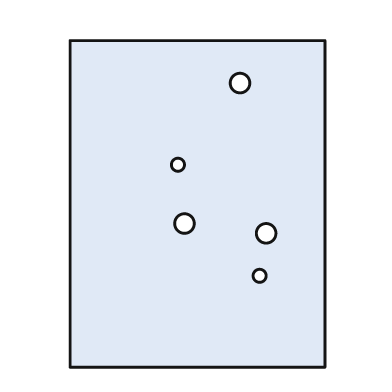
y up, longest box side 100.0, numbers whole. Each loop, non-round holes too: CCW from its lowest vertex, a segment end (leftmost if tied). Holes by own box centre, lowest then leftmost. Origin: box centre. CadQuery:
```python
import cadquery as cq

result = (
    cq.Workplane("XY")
    .moveTo(-39.0, -50.0)
    .lineTo(39.0, -50.0)
    .lineTo(39.0, 50.0)
    .lineTo(-39.0, 50.0)
    .close()
    .moveTo(19.0, -22.0)
    .circle(2.0)
    .moveTo(21.0, -9.0)
    .circle(3.0)
    .moveTo(-4.0, -6.0)
    .circle(3.0)
    .moveTo(-6.0, 12.0)
    .circle(2.0)
    .moveTo(13.0, 37.0)
    .circle(3.0)
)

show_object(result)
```